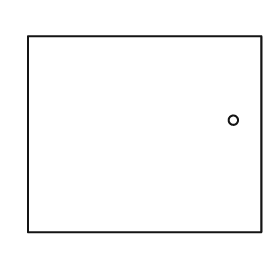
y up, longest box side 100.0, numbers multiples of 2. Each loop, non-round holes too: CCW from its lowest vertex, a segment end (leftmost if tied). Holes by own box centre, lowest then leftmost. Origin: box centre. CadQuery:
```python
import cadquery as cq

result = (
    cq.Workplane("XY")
    .moveTo(-50.0, -42.0)
    .lineTo(50.0, -42.0)
    .lineTo(50.0, 42.0)
    .lineTo(-50.0, 42.0)
    .close()
    .moveTo(38.0, 6.0)
    .circle(2.0)
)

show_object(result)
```